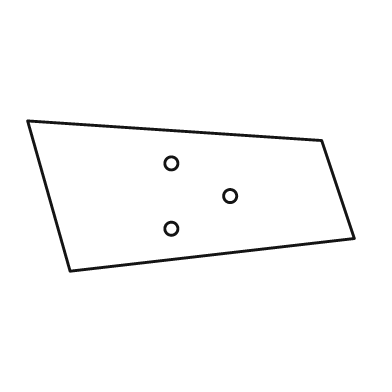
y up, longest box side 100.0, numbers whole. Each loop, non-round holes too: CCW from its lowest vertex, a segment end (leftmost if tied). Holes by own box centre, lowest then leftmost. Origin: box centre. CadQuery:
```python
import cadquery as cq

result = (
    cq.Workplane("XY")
    .moveTo(-37.0, -23.0)
    .lineTo(50.0, -13.0)
    .lineTo(40.0, 17.0)
    .lineTo(-50.0, 23.0)
    .close()
    .moveTo(-6.0, -10.0)
    .circle(2.0)
    .moveTo(12.0, 0.0)
    .circle(2.0)
    .moveTo(-6.0, 10.0)
    .circle(2.0)
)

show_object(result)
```